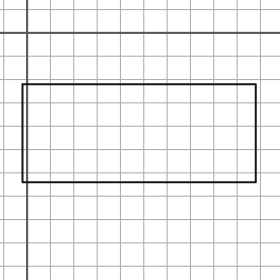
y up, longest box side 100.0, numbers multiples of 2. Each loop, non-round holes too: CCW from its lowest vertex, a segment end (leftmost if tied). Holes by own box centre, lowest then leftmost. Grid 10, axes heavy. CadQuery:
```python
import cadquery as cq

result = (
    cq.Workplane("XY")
    .moveTo(-2.0, -64.0)
    .lineTo(98.0, -64.0)
    .lineTo(98.0, -22.0)
    .lineTo(-2.0, -22.0)
    .close()
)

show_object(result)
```